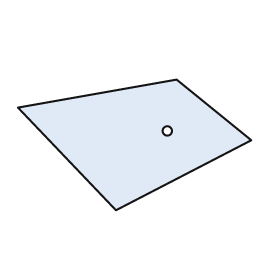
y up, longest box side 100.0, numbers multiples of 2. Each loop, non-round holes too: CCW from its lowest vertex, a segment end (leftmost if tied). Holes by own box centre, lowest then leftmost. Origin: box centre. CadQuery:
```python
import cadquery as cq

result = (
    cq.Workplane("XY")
    .moveTo(-8.0, -28.0)
    .lineTo(50.0, 2.0)
    .lineTo(18.0, 28.0)
    .lineTo(-50.0, 16.0)
    .close()
    .moveTo(14.0, 6.0)
    .circle(2.0)
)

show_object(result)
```